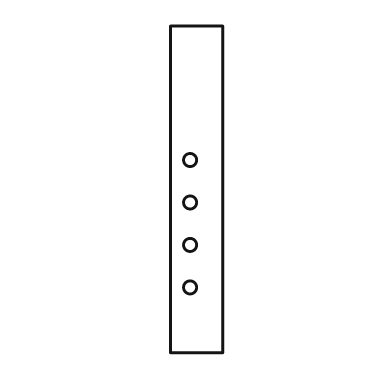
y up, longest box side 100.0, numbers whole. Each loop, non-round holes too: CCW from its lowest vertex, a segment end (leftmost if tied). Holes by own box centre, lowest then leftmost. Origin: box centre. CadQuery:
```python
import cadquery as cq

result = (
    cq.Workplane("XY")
    .moveTo(-8.0, -50.0)
    .lineTo(8.0, -50.0)
    .lineTo(8.0, 50.0)
    .lineTo(-8.0, 50.0)
    .close()
    .moveTo(-2.0, -30.0)
    .circle(2.0)
    .moveTo(-2.0, -17.0)
    .circle(2.0)
    .moveTo(-2.0, -4.0)
    .circle(2.0)
    .moveTo(-2.0, 9.0)
    .circle(2.0)
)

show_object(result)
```